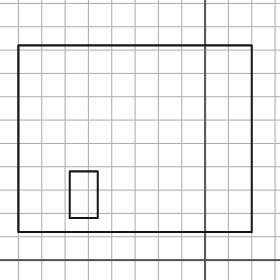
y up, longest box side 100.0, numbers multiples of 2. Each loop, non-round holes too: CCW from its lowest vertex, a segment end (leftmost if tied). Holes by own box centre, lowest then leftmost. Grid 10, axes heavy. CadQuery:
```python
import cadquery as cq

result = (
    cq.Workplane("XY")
    .moveTo(-80.0, 12.0)
    .lineTo(20.0, 12.0)
    .lineTo(20.0, 92.0)
    .lineTo(-80.0, 92.0)
    .close()
    .moveTo(-58.0, 18.0)
    .lineTo(-46.0, 18.0)
    .lineTo(-46.0, 38.0)
    .lineTo(-58.0, 38.0)
    .close()
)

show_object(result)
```